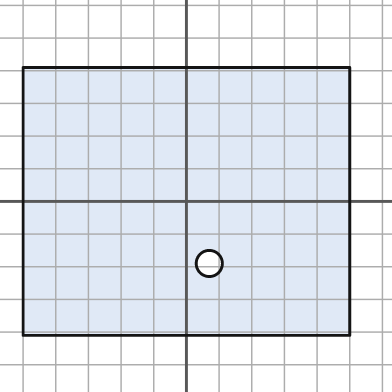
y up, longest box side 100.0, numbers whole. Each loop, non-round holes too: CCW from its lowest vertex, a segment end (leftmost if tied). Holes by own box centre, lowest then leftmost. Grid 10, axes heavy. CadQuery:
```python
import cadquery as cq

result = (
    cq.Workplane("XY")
    .moveTo(-50.0, -41.0)
    .lineTo(50.0, -41.0)
    .lineTo(50.0, 41.0)
    .lineTo(-50.0, 41.0)
    .close()
    .moveTo(7.0, -19.0)
    .circle(4.0)
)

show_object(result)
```